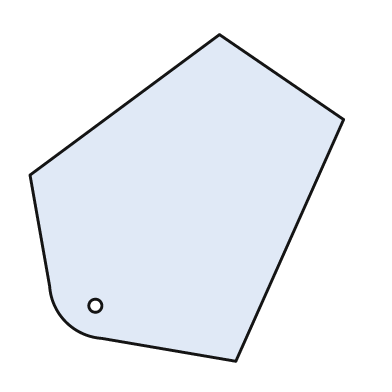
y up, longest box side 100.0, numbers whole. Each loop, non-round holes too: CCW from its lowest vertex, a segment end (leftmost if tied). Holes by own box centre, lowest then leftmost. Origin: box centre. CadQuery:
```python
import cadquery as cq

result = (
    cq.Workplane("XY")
    .moveTo(15.0, -50.0)
    .lineTo(48.0, 24.0)
    .lineTo(10.0, 50.0)
    .lineTo(-48.0, 7.0)
    .lineTo(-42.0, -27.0)
    .threePointArc((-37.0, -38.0), (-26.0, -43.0))
    .close()
    .moveTo(-28.0, -33.0)
    .circle(2.0)
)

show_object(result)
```